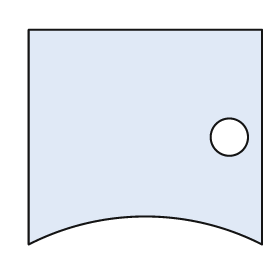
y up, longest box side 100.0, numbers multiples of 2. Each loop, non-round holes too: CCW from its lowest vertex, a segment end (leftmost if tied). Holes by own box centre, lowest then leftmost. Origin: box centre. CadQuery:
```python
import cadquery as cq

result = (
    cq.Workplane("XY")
    .moveTo(-50.0, -46.0)
    .threePointArc((0.0, -34.0), (50.0, -46.0))
    .lineTo(50.0, 46.0)
    .lineTo(-50.0, 46.0)
    .close()
    .moveTo(36.0, 0.0)
    .circle(8.0)
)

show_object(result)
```